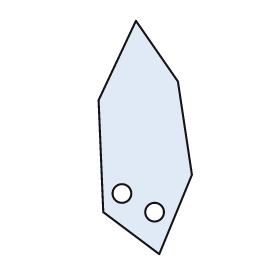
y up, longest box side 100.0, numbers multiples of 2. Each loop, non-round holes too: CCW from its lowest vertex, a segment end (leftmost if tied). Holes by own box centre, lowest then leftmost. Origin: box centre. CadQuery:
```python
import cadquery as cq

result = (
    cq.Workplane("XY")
    .moveTo(6.0, -50.0)
    .lineTo(20.0, -16.0)
    .lineTo(14.0, 24.0)
    .lineTo(-4.0, 50.0)
    .lineTo(-20.0, 16.0)
    .lineTo(-18.0, -32.0)
    .close()
    .moveTo(4.0, -32.0)
    .circle(4.0)
    .moveTo(-10.0, -24.0)
    .circle(4.0)
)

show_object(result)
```